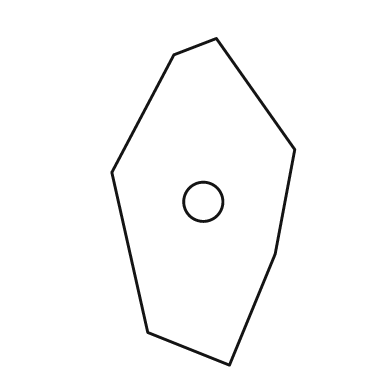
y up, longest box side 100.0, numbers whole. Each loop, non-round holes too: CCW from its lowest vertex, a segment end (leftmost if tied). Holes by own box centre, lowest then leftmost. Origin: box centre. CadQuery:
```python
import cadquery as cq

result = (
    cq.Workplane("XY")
    .moveTo(8.0, -50.0)
    .lineTo(22.0, -16.0)
    .lineTo(28.0, 16.0)
    .lineTo(4.0, 50.0)
    .lineTo(-9.0, 45.0)
    .lineTo(-28.0, 9.0)
    .lineTo(-17.0, -40.0)
    .close()
    .moveTo(0.0, 0.0)
    .circle(6.0)
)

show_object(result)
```